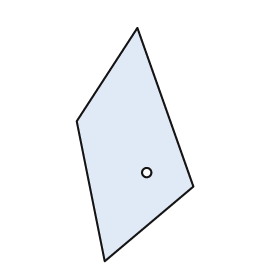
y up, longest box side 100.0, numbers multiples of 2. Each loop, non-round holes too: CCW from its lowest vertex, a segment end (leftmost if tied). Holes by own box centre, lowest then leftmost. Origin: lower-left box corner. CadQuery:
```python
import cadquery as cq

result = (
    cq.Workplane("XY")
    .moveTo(12.0, 0.0)
    .lineTo(50.0, 32.0)
    .lineTo(26.0, 100.0)
    .lineTo(0.0, 60.0)
    .close()
    .moveTo(30.0, 38.0)
    .circle(2.0)
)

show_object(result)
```